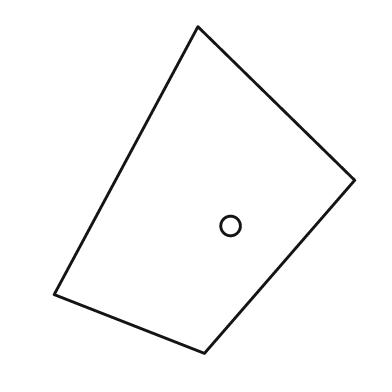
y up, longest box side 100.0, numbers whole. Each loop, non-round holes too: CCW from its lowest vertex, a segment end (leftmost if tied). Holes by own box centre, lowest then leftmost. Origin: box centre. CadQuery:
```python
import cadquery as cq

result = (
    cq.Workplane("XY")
    .moveTo(0.0, -50.0)
    .lineTo(46.0, 3.0)
    .lineTo(-2.0, 50.0)
    .lineTo(-46.0, -32.0)
    .close()
    .moveTo(8.0, -11.0)
    .circle(3.0)
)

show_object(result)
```